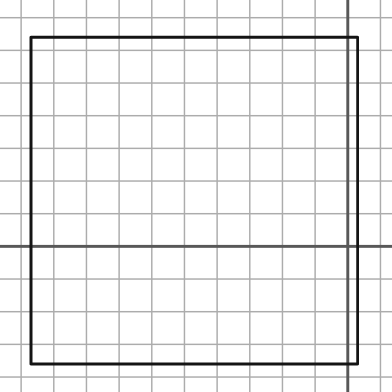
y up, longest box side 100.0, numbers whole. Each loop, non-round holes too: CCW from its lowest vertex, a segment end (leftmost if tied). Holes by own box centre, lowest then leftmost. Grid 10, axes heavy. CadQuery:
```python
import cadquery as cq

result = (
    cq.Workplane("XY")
    .moveTo(-97.0, -36.0)
    .lineTo(3.0, -36.0)
    .lineTo(3.0, 64.0)
    .lineTo(-97.0, 64.0)
    .close()
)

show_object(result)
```